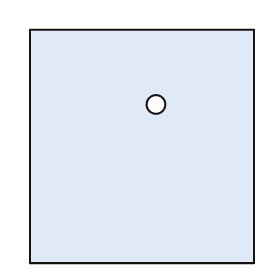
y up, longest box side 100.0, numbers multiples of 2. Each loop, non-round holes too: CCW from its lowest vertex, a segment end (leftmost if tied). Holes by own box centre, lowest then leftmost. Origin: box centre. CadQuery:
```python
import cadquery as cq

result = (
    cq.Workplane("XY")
    .moveTo(-48.0, -50.0)
    .lineTo(48.0, -50.0)
    .lineTo(48.0, 50.0)
    .lineTo(-48.0, 50.0)
    .close()
    .moveTo(6.0, 18.0)
    .circle(4.0)
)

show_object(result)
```